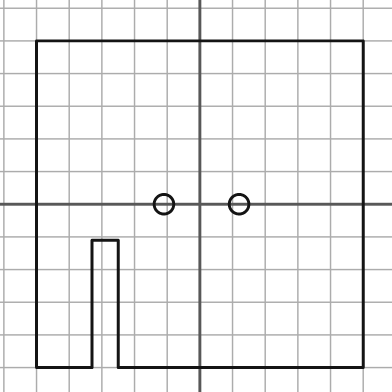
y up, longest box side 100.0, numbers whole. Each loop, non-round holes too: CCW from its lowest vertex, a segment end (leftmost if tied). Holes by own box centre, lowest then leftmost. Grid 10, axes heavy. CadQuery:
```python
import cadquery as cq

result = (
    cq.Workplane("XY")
    .moveTo(-50.0, -50.0)
    .lineTo(-33.0, -50.0)
    .lineTo(-33.0, -11.0)
    .lineTo(-25.0, -11.0)
    .lineTo(-25.0, -50.0)
    .lineTo(50.0, -50.0)
    .lineTo(50.0, 50.0)
    .lineTo(-50.0, 50.0)
    .close()
    .moveTo(-11.0, 0.0)
    .circle(3.0)
    .moveTo(12.0, 0.0)
    .circle(3.0)
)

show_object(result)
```